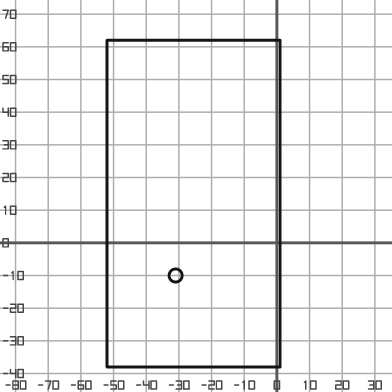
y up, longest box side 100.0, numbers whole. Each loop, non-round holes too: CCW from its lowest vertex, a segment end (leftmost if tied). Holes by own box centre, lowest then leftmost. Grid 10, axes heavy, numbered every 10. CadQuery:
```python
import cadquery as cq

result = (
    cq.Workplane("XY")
    .moveTo(-52.0, -38.0)
    .lineTo(1.0, -38.0)
    .lineTo(1.0, 62.0)
    .lineTo(-52.0, 62.0)
    .close()
    .moveTo(-31.0, -10.0)
    .circle(2.0)
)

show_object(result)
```